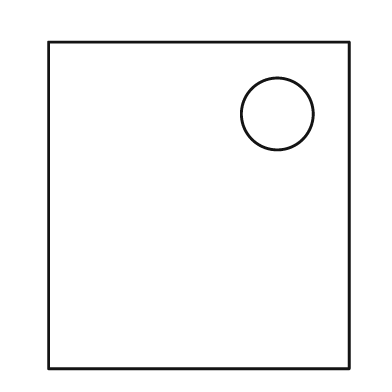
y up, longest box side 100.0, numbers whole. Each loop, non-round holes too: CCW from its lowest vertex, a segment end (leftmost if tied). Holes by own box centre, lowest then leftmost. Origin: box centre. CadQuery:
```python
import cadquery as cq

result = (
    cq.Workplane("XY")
    .moveTo(-46.0, -50.0)
    .lineTo(46.0, -50.0)
    .lineTo(46.0, 50.0)
    .lineTo(-46.0, 50.0)
    .close()
    .moveTo(24.0, 28.0)
    .circle(11.0)
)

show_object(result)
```